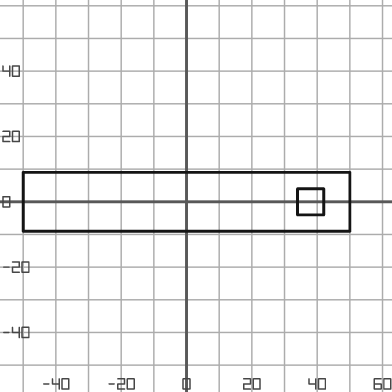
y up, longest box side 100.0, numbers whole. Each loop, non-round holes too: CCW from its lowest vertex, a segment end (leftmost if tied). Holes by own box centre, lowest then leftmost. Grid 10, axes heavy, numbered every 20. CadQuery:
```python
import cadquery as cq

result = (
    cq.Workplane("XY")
    .moveTo(-50.0, -9.0)
    .lineTo(50.0, -9.0)
    .lineTo(50.0, 9.0)
    .lineTo(-50.0, 9.0)
    .close()
    .moveTo(34.0, -4.0)
    .lineTo(42.0, -4.0)
    .lineTo(42.0, 4.0)
    .lineTo(34.0, 4.0)
    .close()
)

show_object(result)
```